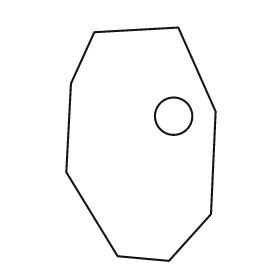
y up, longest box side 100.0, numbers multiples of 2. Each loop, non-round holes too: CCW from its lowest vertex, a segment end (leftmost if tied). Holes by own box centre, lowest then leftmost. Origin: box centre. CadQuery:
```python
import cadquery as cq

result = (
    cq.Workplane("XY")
    .moveTo(12.0, -50.0)
    .lineTo(30.0, -30.0)
    .lineTo(32.0, 14.0)
    .lineTo(16.0, 50.0)
    .lineTo(-20.0, 48.0)
    .lineTo(-30.0, 26.0)
    .lineTo(-32.0, -12.0)
    .lineTo(-10.0, -48.0)
    .close()
    .moveTo(14.0, 12.0)
    .circle(8.0)
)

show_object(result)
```